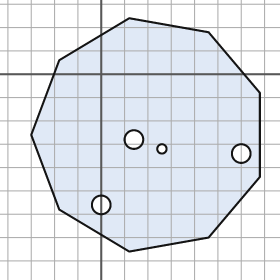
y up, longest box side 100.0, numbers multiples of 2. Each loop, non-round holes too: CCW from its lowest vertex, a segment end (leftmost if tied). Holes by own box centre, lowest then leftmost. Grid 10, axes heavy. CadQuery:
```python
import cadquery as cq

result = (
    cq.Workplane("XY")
    .moveTo(12.0, -76.0)
    .lineTo(46.0, -70.0)
    .lineTo(68.0, -44.0)
    .lineTo(68.0, -8.0)
    .lineTo(46.0, 18.0)
    .lineTo(12.0, 24.0)
    .lineTo(-18.0, 6.0)
    .lineTo(-30.0, -26.0)
    .lineTo(-18.0, -58.0)
    .close()
    .moveTo(0.0, -56.0)
    .circle(4.0)
    .moveTo(60.0, -34.0)
    .circle(4.0)
    .moveTo(26.0, -32.0)
    .circle(2.0)
    .moveTo(14.0, -28.0)
    .circle(4.0)
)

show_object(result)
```